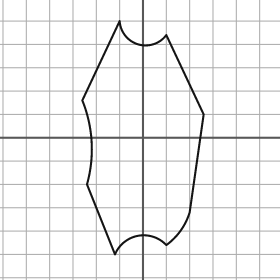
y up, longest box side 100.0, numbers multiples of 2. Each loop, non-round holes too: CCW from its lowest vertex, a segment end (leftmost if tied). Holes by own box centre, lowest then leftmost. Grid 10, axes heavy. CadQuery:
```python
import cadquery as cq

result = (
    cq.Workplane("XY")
    .moveTo(-12.0, -50.0)
    .threePointArc((-2.0, -42.0), (10.0, -46.0))
    .threePointArc((16.0, -40.0), (20.0, -32.0))
    .lineTo(26.0, 10.0)
    .lineTo(10.0, 44.0)
    .threePointArc((-2.0, 40.0), (-10.0, 50.0))
    .lineTo(-26.0, 16.0)
    .threePointArc((-22.0, -2.0), (-24.0, -20.0))
    .close()
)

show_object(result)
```